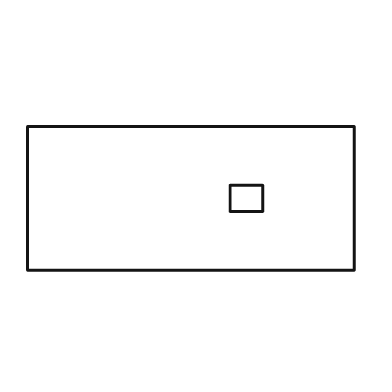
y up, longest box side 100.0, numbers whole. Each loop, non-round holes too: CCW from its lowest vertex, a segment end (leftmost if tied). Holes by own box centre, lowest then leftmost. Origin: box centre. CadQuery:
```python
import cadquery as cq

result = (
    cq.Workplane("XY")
    .moveTo(-50.0, -22.0)
    .lineTo(50.0, -22.0)
    .lineTo(50.0, 22.0)
    .lineTo(-50.0, 22.0)
    .close()
    .moveTo(12.0, -4.0)
    .lineTo(22.0, -4.0)
    .lineTo(22.0, 4.0)
    .lineTo(12.0, 4.0)
    .close()
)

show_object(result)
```